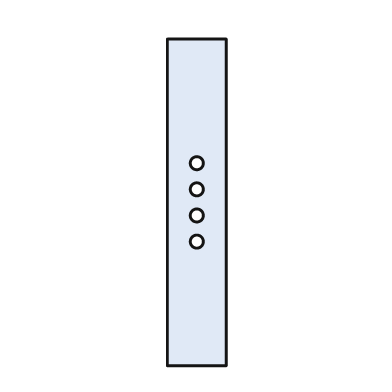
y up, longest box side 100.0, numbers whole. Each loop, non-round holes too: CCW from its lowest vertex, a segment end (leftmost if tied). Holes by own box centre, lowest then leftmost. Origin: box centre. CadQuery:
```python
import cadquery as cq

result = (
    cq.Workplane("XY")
    .moveTo(-9.0, -50.0)
    .lineTo(9.0, -50.0)
    .lineTo(9.0, 50.0)
    .lineTo(-9.0, 50.0)
    .close()
    .moveTo(0.0, -12.0)
    .circle(2.0)
    .moveTo(0.0, -4.0)
    .circle(2.0)
    .moveTo(0.0, 4.0)
    .circle(2.0)
    .moveTo(0.0, 12.0)
    .circle(2.0)
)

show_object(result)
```